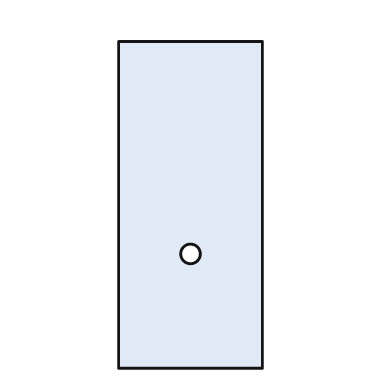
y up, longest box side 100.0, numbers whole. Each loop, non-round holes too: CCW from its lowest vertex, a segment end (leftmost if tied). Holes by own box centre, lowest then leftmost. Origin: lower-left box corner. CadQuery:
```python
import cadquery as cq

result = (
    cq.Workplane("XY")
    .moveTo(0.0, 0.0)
    .lineTo(44.0, 0.0)
    .lineTo(44.0, 100.0)
    .lineTo(0.0, 100.0)
    .close()
    .moveTo(22.0, 35.0)
    .circle(3.0)
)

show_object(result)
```